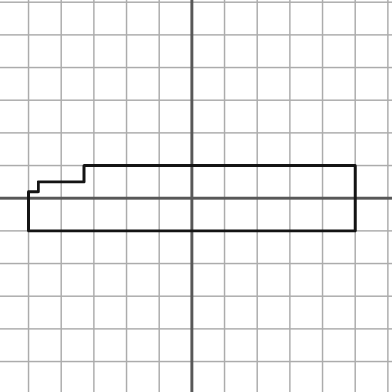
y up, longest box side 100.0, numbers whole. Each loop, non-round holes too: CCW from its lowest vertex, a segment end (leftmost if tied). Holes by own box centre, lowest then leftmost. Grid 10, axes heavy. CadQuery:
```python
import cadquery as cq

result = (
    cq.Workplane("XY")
    .moveTo(-50.0, -10.0)
    .lineTo(50.0, -10.0)
    .lineTo(50.0, 10.0)
    .lineTo(-33.0, 10.0)
    .lineTo(-33.0, 5.0)
    .lineTo(-47.0, 5.0)
    .lineTo(-47.0, 2.0)
    .lineTo(-50.0, 2.0)
    .close()
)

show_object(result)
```